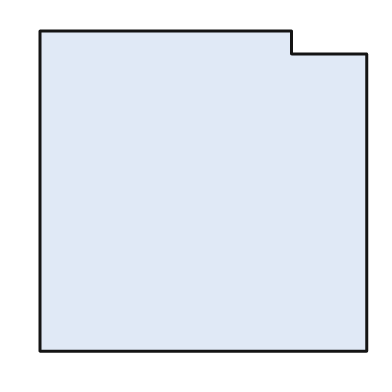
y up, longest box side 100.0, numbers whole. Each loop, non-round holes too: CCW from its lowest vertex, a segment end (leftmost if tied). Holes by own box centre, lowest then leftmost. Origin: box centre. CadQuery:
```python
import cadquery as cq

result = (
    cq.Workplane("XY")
    .moveTo(-50.0, -49.0)
    .lineTo(50.0, -49.0)
    .lineTo(50.0, 42.0)
    .lineTo(27.0, 42.0)
    .lineTo(27.0, 49.0)
    .lineTo(-50.0, 49.0)
    .close()
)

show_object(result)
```